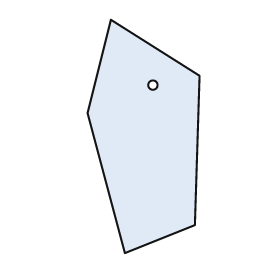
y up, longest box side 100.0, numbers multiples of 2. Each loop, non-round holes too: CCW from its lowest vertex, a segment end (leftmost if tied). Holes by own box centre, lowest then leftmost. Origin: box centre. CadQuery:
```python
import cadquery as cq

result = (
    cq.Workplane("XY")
    .moveTo(-8.0, -50.0)
    .lineTo(22.0, -38.0)
    .lineTo(24.0, 26.0)
    .lineTo(-14.0, 50.0)
    .lineTo(-24.0, 10.0)
    .close()
    .moveTo(4.0, 22.0)
    .circle(2.0)
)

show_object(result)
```